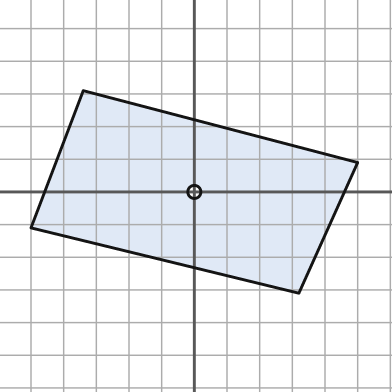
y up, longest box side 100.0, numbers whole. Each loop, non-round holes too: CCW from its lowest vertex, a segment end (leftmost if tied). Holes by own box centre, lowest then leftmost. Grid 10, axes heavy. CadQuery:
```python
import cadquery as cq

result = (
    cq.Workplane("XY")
    .moveTo(32.0, -31.0)
    .lineTo(50.0, 9.0)
    .lineTo(-34.0, 31.0)
    .lineTo(-50.0, -11.0)
    .close()
    .moveTo(0.0, 0.0)
    .circle(2.0)
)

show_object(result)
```